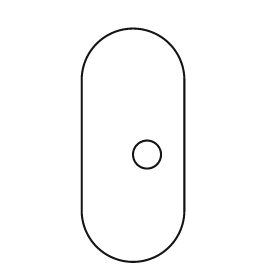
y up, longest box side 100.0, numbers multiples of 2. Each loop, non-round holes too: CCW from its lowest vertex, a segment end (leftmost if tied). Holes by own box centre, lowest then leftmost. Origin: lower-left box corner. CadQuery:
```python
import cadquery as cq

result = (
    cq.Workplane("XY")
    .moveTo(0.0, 22.0)
    .threePointArc((22.0, 0.0), (44.0, 22.0))
    .lineTo(44.0, 78.0)
    .threePointArc((22.0, 100.0), (0.0, 78.0))
    .close()
    .moveTo(28.0, 46.0)
    .circle(6.0)
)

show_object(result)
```